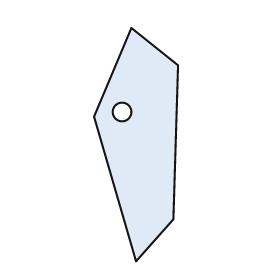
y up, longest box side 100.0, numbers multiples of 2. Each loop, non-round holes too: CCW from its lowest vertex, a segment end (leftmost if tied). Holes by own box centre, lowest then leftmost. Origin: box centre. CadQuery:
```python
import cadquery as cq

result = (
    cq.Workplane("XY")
    .moveTo(0.0, -50.0)
    .lineTo(16.0, -32.0)
    .lineTo(18.0, 34.0)
    .lineTo(-2.0, 50.0)
    .lineTo(-18.0, 12.0)
    .close()
    .moveTo(-6.0, 14.0)
    .circle(4.0)
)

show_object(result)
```